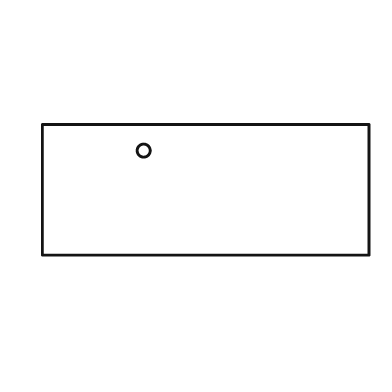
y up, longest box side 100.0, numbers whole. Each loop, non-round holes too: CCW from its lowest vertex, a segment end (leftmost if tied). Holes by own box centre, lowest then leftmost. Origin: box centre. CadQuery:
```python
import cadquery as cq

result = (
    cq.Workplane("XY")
    .moveTo(-50.0, -20.0)
    .lineTo(50.0, -20.0)
    .lineTo(50.0, 20.0)
    .lineTo(-50.0, 20.0)
    .close()
    .moveTo(-19.0, 12.0)
    .circle(2.0)
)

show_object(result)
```